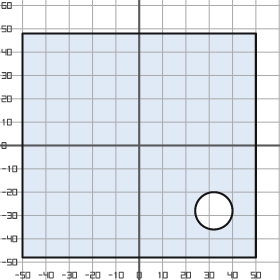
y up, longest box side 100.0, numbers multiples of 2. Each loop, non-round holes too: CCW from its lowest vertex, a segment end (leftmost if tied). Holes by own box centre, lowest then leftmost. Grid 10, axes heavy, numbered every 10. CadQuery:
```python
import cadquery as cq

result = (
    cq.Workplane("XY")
    .moveTo(-50.0, -48.0)
    .lineTo(50.0, -48.0)
    .lineTo(50.0, 48.0)
    .lineTo(-50.0, 48.0)
    .close()
    .moveTo(32.0, -28.0)
    .circle(8.0)
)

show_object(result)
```